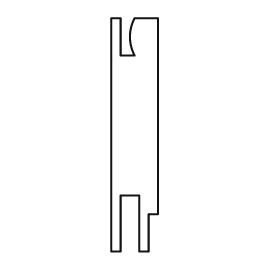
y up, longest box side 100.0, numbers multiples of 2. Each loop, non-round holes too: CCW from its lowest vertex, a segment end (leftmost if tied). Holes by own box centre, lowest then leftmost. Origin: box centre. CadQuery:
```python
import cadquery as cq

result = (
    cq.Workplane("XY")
    .moveTo(-10.0, -50.0)
    .lineTo(-6.0, -50.0)
    .lineTo(-6.0, -26.0)
    .lineTo(2.0, -26.0)
    .lineTo(2.0, -50.0)
    .lineTo(6.0, -50.0)
    .lineTo(6.0, -34.0)
    .lineTo(10.0, -34.0)
    .lineTo(10.0, 50.0)
    .lineTo(0.0, 50.0)
    .threePointArc((-2.0, 42.0), (0.0, 34.0))
    .lineTo(-6.0, 34.0)
    .lineTo(-6.0, 50.0)
    .lineTo(-10.0, 50.0)
    .close()
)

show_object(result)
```